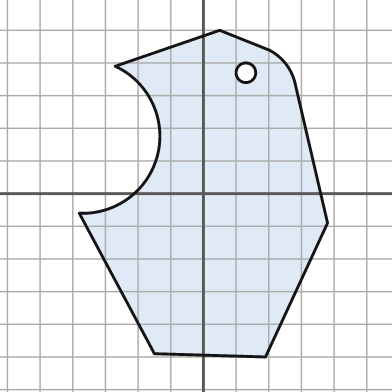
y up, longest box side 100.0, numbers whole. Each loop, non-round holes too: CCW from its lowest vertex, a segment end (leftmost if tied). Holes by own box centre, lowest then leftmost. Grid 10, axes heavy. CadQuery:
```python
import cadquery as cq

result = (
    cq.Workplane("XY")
    .moveTo(19.0, -50.0)
    .lineTo(38.0, -9.0)
    .lineTo(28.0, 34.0)
    .threePointArc((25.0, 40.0), (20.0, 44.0))
    .lineTo(5.0, 50.0)
    .lineTo(-27.0, 39.0)
    .threePointArc((-14.0, 12.0), (-38.0, -6.0))
    .lineTo(-15.0, -49.0)
    .close()
    .moveTo(13.0, 37.0)
    .circle(3.0)
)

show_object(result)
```